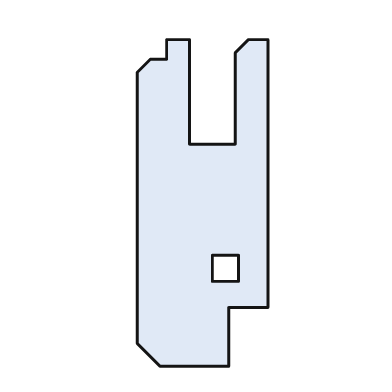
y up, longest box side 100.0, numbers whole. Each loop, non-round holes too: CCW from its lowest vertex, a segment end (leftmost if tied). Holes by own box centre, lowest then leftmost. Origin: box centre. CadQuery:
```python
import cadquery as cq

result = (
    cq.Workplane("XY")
    .moveTo(-13.0, -50.0)
    .lineTo(8.0, -50.0)
    .lineTo(8.0, -32.0)
    .lineTo(20.0, -32.0)
    .lineTo(20.0, 50.0)
    .lineTo(14.0, 50.0)
    .lineTo(10.0, 46.0)
    .lineTo(10.0, 18.0)
    .lineTo(-4.0, 18.0)
    .lineTo(-4.0, 50.0)
    .lineTo(-11.0, 50.0)
    .lineTo(-11.0, 44.0)
    .lineTo(-16.0, 44.0)
    .lineTo(-20.0, 40.0)
    .lineTo(-20.0, -43.0)
    .close()
    .moveTo(3.0, -24.0)
    .lineTo(11.0, -24.0)
    .lineTo(11.0, -16.0)
    .lineTo(3.0, -16.0)
    .close()
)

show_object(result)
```